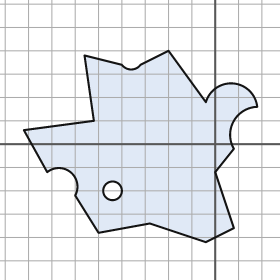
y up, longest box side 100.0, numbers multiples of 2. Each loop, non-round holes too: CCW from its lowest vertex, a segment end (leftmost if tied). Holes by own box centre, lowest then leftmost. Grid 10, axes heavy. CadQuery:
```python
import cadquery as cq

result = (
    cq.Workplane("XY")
    .moveTo(-4.0, -42.0)
    .lineTo(8.0, -36.0)
    .lineTo(0.0, -12.0)
    .lineTo(8.0, -2.0)
    .threePointArc((8.0, 10.0), (18.0, 16.0))
    .threePointArc((8.0, 26.0), (-4.0, 18.0))
    .lineTo(-20.0, 40.0)
    .lineTo(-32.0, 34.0)
    .threePointArc((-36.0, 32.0), (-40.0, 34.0))
    .lineTo(-56.0, 38.0)
    .lineTo(-52.0, 10.0)
    .lineTo(-82.0, 6.0)
    .lineTo(-72.0, -12.0)
    .threePointArc((-62.0, -12.0), (-60.0, -22.0))
    .lineTo(-50.0, -38.0)
    .lineTo(-28.0, -34.0)
    .close()
    .moveTo(-44.0, -20.0)
    .circle(4.0)
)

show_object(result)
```